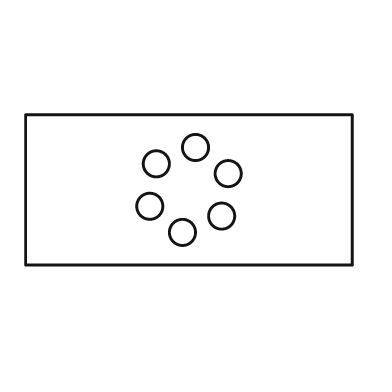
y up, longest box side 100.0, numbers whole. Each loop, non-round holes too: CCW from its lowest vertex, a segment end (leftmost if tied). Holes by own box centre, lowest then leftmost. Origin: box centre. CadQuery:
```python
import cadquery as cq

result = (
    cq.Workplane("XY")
    .moveTo(-50.0, -23.0)
    .lineTo(50.0, -23.0)
    .lineTo(50.0, 23.0)
    .lineTo(-50.0, 23.0)
    .close()
    .moveTo(-2.0, -13.0)
    .circle(4.0)
    .moveTo(10.0, -8.0)
    .circle(4.0)
    .moveTo(-12.0, -5.0)
    .circle(4.0)
    .moveTo(12.0, 5.0)
    .circle(4.0)
    .moveTo(-10.0, 8.0)
    .circle(4.0)
    .moveTo(2.0, 13.0)
    .circle(4.0)
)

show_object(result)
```